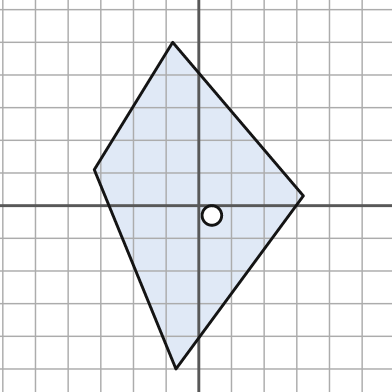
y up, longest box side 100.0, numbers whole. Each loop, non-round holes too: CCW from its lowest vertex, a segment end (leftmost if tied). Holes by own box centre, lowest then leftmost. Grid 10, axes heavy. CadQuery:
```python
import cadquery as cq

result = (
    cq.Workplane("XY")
    .moveTo(-7.0, -50.0)
    .lineTo(32.0, 3.0)
    .lineTo(-8.0, 50.0)
    .lineTo(-32.0, 11.0)
    .close()
    .moveTo(4.0, -3.0)
    .circle(3.0)
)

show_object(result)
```